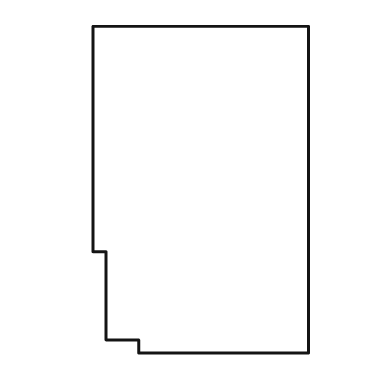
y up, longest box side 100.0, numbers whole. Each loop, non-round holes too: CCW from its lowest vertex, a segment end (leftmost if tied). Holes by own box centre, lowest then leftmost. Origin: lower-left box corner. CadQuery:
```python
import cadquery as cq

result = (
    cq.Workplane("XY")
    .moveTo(14.0, 0.0)
    .lineTo(66.0, 0.0)
    .lineTo(66.0, 100.0)
    .lineTo(0.0, 100.0)
    .lineTo(0.0, 31.0)
    .lineTo(4.0, 31.0)
    .lineTo(4.0, 4.0)
    .lineTo(14.0, 4.0)
    .close()
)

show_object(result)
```